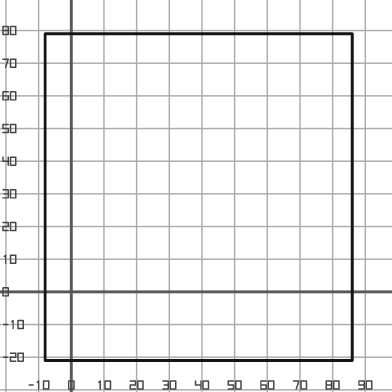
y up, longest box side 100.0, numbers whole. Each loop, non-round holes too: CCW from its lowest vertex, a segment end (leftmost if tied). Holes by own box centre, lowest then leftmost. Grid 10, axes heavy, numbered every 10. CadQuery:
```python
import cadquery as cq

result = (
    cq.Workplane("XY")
    .moveTo(-8.0, -21.0)
    .lineTo(86.0, -21.0)
    .lineTo(86.0, 79.0)
    .lineTo(-8.0, 79.0)
    .close()
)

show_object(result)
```